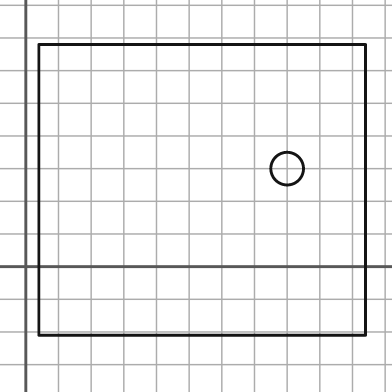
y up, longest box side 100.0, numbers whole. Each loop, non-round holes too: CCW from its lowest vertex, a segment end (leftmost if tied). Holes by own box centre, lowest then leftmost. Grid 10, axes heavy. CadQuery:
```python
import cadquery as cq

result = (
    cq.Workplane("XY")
    .moveTo(4.0, -21.0)
    .lineTo(104.0, -21.0)
    .lineTo(104.0, 68.0)
    .lineTo(4.0, 68.0)
    .close()
    .moveTo(80.0, 30.0)
    .circle(5.0)
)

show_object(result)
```